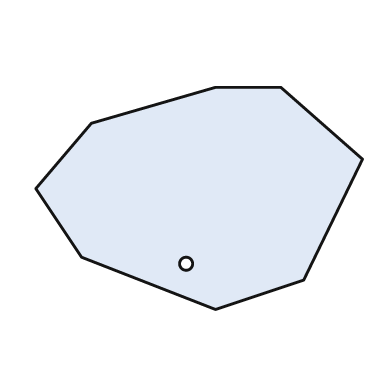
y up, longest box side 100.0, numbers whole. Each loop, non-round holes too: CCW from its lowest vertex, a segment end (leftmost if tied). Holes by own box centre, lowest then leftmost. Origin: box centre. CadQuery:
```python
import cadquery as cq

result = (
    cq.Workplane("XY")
    .moveTo(5.0, -34.0)
    .lineTo(32.0, -25.0)
    .lineTo(50.0, 12.0)
    .lineTo(25.0, 34.0)
    .lineTo(5.0, 34.0)
    .lineTo(-33.0, 23.0)
    .lineTo(-50.0, 3.0)
    .lineTo(-36.0, -18.0)
    .close()
    .moveTo(-4.0, -20.0)
    .circle(2.0)
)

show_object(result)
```